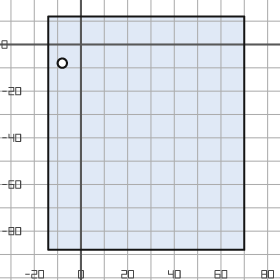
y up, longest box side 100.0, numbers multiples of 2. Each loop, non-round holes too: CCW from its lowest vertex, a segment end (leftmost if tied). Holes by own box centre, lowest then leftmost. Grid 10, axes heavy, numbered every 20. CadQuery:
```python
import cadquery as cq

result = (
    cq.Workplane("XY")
    .moveTo(-14.0, -88.0)
    .lineTo(70.0, -88.0)
    .lineTo(70.0, 12.0)
    .lineTo(-14.0, 12.0)
    .close()
    .moveTo(-8.0, -8.0)
    .circle(2.0)
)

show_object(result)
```